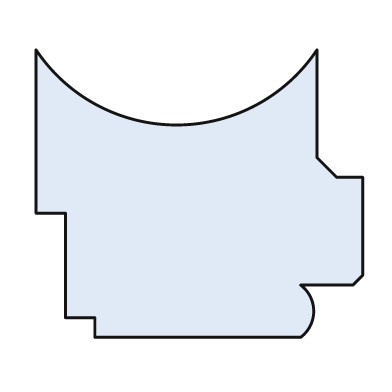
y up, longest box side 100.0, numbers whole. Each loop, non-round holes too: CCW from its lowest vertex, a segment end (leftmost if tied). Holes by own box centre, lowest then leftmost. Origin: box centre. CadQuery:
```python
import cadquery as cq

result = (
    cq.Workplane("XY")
    .moveTo(-32.0, -44.0)
    .lineTo(31.0, -44.0)
    .threePointArc((35.0, -36.0), (31.0, -28.0))
    .lineTo(47.0, -28.0)
    .lineTo(50.0, -25.0)
    .lineTo(50.0, 5.0)
    .lineTo(42.0, 5.0)
    .lineTo(36.0, 11.0)
    .lineTo(36.0, 44.0)
    .threePointArc((-7.0, 21.0), (-50.0, 44.0))
    .lineTo(-50.0, -6.0)
    .lineTo(-41.0, -6.0)
    .lineTo(-41.0, -38.0)
    .lineTo(-32.0, -38.0)
    .close()
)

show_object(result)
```